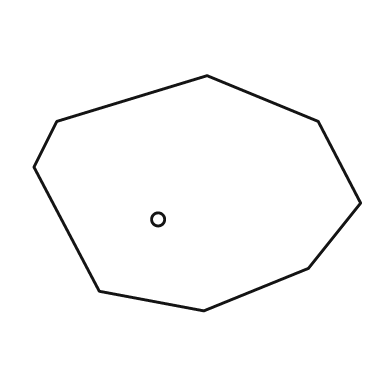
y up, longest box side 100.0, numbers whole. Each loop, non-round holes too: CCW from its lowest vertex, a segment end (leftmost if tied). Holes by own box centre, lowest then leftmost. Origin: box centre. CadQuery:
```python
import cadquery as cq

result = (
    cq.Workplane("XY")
    .moveTo(2.0, -36.0)
    .lineTo(34.0, -23.0)
    .lineTo(50.0, -3.0)
    .lineTo(37.0, 22.0)
    .lineTo(3.0, 36.0)
    .lineTo(-43.0, 22.0)
    .lineTo(-50.0, 8.0)
    .lineTo(-30.0, -30.0)
    .close()
    .moveTo(-12.0, -8.0)
    .circle(2.0)
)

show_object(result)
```